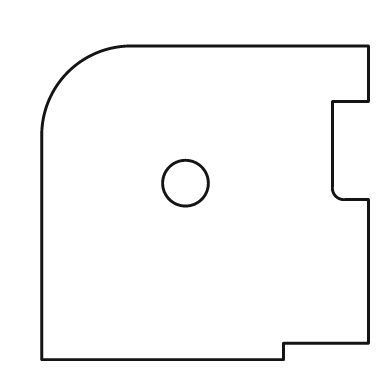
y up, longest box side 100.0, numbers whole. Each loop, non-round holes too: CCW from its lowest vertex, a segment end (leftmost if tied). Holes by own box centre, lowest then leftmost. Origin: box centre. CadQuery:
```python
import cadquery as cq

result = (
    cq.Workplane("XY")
    .moveTo(-50.0, -48.0)
    .lineTo(24.0, -48.0)
    .lineTo(24.0, -43.0)
    .lineTo(50.0, -43.0)
    .lineTo(50.0, 1.0)
    .lineTo(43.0, 1.0)
    .threePointArc((40.0, 2.0), (39.0, 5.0))
    .lineTo(39.0, 31.0)
    .lineTo(50.0, 31.0)
    .lineTo(50.0, 48.0)
    .lineTo(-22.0, 48.0)
    .threePointArc((-42.0, 40.0), (-50.0, 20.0))
    .close()
    .moveTo(-6.0, 6.0)
    .circle(7.0)
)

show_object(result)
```